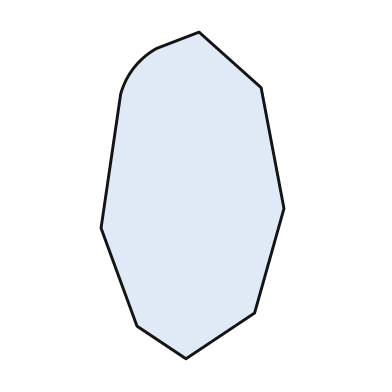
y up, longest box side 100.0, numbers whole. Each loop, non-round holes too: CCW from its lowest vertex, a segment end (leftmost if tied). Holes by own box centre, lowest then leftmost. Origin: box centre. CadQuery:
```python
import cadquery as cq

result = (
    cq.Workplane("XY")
    .moveTo(-2.0, -50.0)
    .lineTo(19.0, -36.0)
    .lineTo(28.0, -4.0)
    .lineTo(21.0, 33.0)
    .lineTo(2.0, 50.0)
    .lineTo(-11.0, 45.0)
    .threePointArc((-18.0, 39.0), (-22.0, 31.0))
    .lineTo(-28.0, -10.0)
    .lineTo(-17.0, -40.0)
    .close()
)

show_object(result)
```